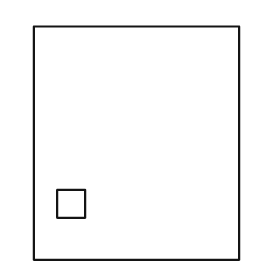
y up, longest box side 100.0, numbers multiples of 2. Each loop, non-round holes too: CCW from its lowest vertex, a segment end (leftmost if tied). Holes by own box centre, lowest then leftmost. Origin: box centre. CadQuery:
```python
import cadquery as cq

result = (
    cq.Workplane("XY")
    .moveTo(-44.0, -50.0)
    .lineTo(44.0, -50.0)
    .lineTo(44.0, 50.0)
    .lineTo(-44.0, 50.0)
    .close()
    .moveTo(-34.0, -32.0)
    .lineTo(-22.0, -32.0)
    .lineTo(-22.0, -20.0)
    .lineTo(-34.0, -20.0)
    .close()
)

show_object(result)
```